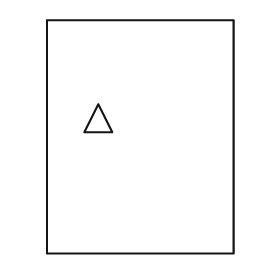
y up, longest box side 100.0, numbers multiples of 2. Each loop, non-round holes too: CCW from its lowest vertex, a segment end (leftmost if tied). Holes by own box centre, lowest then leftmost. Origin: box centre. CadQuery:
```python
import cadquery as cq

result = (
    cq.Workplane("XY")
    .moveTo(-40.0, -50.0)
    .lineTo(40.0, -50.0)
    .lineTo(40.0, 50.0)
    .lineTo(-40.0, 50.0)
    .close()
    .moveTo(-24.0, 2.0)
    .lineTo(-12.0, 2.0)
    .lineTo(-18.0, 14.0)
    .close()
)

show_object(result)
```